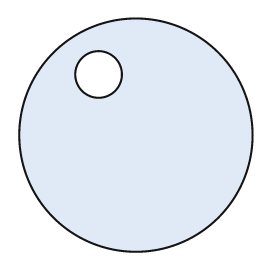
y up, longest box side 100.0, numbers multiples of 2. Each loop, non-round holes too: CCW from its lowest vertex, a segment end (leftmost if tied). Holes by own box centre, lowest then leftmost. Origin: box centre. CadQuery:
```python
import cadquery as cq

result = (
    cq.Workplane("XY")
    .moveTo(0.0, 0.0)
    .circle(50.0)
    .moveTo(-16.0, 26.0)
    .circle(10.0)
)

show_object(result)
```